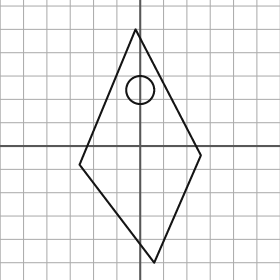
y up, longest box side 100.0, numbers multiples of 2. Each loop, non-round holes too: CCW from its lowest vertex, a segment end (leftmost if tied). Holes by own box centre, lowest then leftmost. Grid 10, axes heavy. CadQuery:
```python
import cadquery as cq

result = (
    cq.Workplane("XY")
    .moveTo(6.0, -50.0)
    .lineTo(26.0, -4.0)
    .lineTo(-2.0, 50.0)
    .lineTo(-26.0, -8.0)
    .close()
    .moveTo(0.0, 24.0)
    .circle(6.0)
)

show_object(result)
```